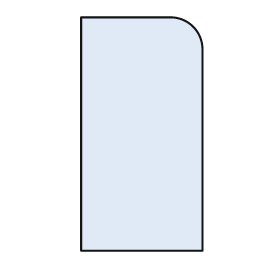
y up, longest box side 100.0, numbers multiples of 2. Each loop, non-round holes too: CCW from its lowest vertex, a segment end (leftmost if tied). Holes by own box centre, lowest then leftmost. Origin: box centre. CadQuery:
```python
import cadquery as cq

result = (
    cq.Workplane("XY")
    .moveTo(-26.0, -50.0)
    .lineTo(26.0, -50.0)
    .lineTo(26.0, 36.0)
    .threePointArc((22.0, 46.0), (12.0, 50.0))
    .lineTo(-26.0, 50.0)
    .close()
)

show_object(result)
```